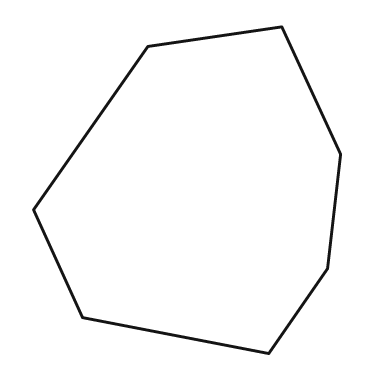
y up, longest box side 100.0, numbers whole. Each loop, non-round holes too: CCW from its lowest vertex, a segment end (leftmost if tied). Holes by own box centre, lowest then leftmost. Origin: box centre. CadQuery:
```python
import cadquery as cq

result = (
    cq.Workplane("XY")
    .moveTo(25.0, -50.0)
    .lineTo(43.0, -24.0)
    .lineTo(47.0, 11.0)
    .lineTo(29.0, 50.0)
    .lineTo(-12.0, 44.0)
    .lineTo(-47.0, -6.0)
    .lineTo(-32.0, -39.0)
    .close()
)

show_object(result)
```